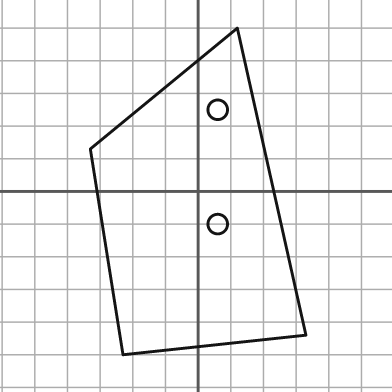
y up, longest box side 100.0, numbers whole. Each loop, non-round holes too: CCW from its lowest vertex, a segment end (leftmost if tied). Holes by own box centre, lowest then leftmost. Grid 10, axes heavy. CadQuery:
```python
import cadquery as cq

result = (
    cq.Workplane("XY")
    .moveTo(-23.0, -50.0)
    .lineTo(33.0, -44.0)
    .lineTo(12.0, 50.0)
    .lineTo(-33.0, 13.0)
    .close()
    .moveTo(6.0, -10.0)
    .circle(3.0)
    .moveTo(6.0, 25.0)
    .circle(3.0)
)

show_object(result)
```